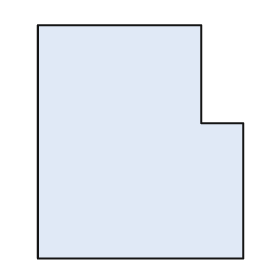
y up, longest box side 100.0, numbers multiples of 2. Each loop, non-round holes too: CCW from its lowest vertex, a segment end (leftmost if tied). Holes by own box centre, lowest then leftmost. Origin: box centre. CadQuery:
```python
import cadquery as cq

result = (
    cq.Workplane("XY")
    .moveTo(-44.0, -50.0)
    .lineTo(44.0, -50.0)
    .lineTo(44.0, 8.0)
    .lineTo(26.0, 8.0)
    .lineTo(26.0, 50.0)
    .lineTo(-44.0, 50.0)
    .close()
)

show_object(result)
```